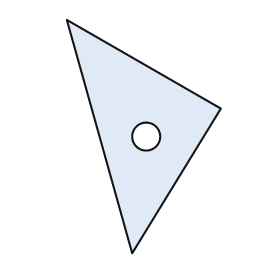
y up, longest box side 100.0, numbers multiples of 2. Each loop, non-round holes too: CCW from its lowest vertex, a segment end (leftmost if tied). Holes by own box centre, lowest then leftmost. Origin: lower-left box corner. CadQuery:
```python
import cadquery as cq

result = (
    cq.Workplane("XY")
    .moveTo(28.0, 0.0)
    .lineTo(66.0, 62.0)
    .lineTo(0.0, 100.0)
    .close()
    .moveTo(34.0, 50.0)
    .circle(6.0)
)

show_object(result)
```